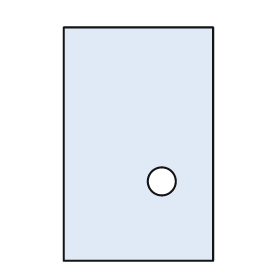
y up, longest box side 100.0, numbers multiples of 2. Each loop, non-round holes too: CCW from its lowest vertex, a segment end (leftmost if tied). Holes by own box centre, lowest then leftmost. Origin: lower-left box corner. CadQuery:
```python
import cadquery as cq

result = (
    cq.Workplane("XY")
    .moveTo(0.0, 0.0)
    .lineTo(64.0, 0.0)
    .lineTo(64.0, 100.0)
    .lineTo(0.0, 100.0)
    .close()
    .moveTo(42.0, 34.0)
    .circle(6.0)
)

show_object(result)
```